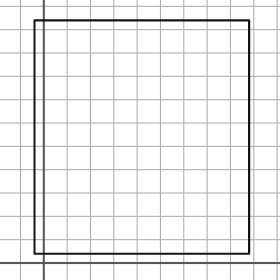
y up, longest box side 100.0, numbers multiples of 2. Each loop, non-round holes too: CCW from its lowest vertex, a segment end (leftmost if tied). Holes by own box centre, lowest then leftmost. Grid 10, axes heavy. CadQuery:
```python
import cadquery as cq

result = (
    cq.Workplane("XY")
    .moveTo(-4.0, 4.0)
    .lineTo(88.0, 4.0)
    .lineTo(88.0, 104.0)
    .lineTo(-4.0, 104.0)
    .close()
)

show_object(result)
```